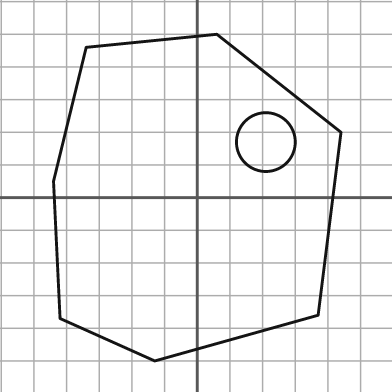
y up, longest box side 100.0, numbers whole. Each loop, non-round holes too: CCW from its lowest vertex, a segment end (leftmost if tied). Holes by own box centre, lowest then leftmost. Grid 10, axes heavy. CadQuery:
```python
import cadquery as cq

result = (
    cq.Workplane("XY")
    .moveTo(-13.0, -50.0)
    .lineTo(37.0, -36.0)
    .lineTo(44.0, 20.0)
    .lineTo(6.0, 50.0)
    .lineTo(-34.0, 46.0)
    .lineTo(-44.0, 5.0)
    .lineTo(-42.0, -37.0)
    .close()
    .moveTo(21.0, 17.0)
    .circle(9.0)
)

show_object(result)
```